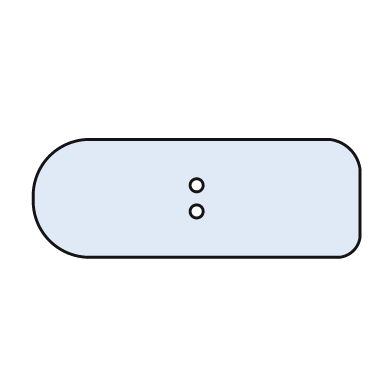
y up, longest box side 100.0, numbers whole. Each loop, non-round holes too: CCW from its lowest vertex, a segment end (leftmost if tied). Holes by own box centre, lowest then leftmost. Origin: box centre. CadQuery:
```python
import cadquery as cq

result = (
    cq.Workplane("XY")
    .moveTo(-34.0, -18.0)
    .lineTo(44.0, -18.0)
    .threePointArc((48.0, -16.0), (50.0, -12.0))
    .lineTo(50.0, 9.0)
    .threePointArc((47.0, 15.0), (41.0, 18.0))
    .lineTo(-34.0, 18.0)
    .threePointArc((-45.0, 13.0), (-50.0, 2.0))
    .lineTo(-50.0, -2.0)
    .threePointArc((-45.0, -13.0), (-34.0, -18.0))
    .close()
    .moveTo(0.0, -4.0)
    .circle(2.0)
    .moveTo(0.0, 4.0)
    .circle(2.0)
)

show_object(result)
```